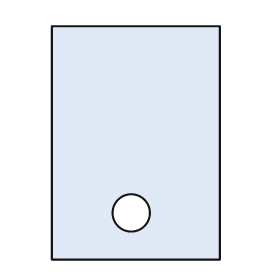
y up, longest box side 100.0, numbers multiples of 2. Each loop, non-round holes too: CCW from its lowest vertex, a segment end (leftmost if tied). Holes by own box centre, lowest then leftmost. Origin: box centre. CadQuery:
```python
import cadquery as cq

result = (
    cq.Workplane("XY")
    .moveTo(-36.0, -50.0)
    .lineTo(36.0, -50.0)
    .lineTo(36.0, 50.0)
    .lineTo(-36.0, 50.0)
    .close()
    .moveTo(-2.0, -30.0)
    .circle(8.0)
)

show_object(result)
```